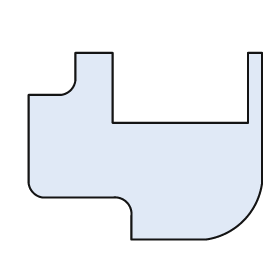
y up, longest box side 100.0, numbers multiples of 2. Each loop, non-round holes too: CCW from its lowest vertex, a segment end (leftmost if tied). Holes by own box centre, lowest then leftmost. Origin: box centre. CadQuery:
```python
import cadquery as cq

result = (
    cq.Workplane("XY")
    .moveTo(-6.0, -40.0)
    .lineTo(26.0, -40.0)
    .threePointArc((42.0, -32.0), (50.0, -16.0))
    .lineTo(50.0, 40.0)
    .lineTo(44.0, 40.0)
    .lineTo(44.0, 10.0)
    .lineTo(-14.0, 10.0)
    .lineTo(-14.0, 40.0)
    .lineTo(-30.0, 40.0)
    .lineTo(-30.0, 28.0)
    .threePointArc((-32.0, 24.0), (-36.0, 22.0))
    .lineTo(-50.0, 22.0)
    .lineTo(-50.0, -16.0)
    .threePointArc((-48.0, -20.0), (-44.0, -22.0))
    .lineTo(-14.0, -22.0)
    .threePointArc((-8.0, -24.0), (-6.0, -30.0))
    .close()
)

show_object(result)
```